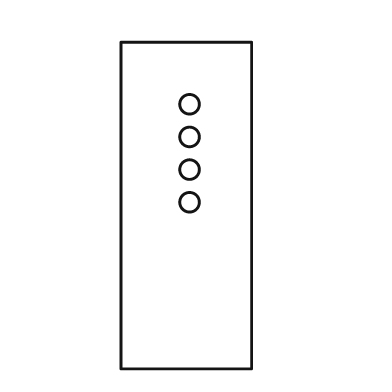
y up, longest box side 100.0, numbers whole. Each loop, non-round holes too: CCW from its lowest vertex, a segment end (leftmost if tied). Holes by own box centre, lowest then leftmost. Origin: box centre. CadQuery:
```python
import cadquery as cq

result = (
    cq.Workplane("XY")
    .moveTo(-20.0, -50.0)
    .lineTo(20.0, -50.0)
    .lineTo(20.0, 50.0)
    .lineTo(-20.0, 50.0)
    .close()
    .moveTo(1.0, 1.0)
    .circle(3.0)
    .moveTo(1.0, 11.0)
    .circle(3.0)
    .moveTo(1.0, 21.0)
    .circle(3.0)
    .moveTo(1.0, 31.0)
    .circle(3.0)
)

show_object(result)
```